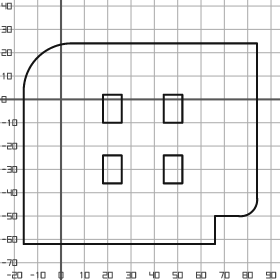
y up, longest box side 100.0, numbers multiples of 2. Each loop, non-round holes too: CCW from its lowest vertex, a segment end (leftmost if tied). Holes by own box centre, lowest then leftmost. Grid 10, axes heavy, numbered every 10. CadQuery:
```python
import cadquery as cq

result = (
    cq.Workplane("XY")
    .moveTo(-16.0, -62.0)
    .lineTo(66.0, -62.0)
    .lineTo(66.0, -50.0)
    .lineTo(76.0, -50.0)
    .threePointArc((82.0, -48.0), (84.0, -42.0))
    .lineTo(84.0, 24.0)
    .lineTo(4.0, 24.0)
    .threePointArc((-10.0, 18.0), (-16.0, 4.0))
    .close()
    .moveTo(18.0, -36.0)
    .lineTo(26.0, -36.0)
    .lineTo(26.0, -24.0)
    .lineTo(18.0, -24.0)
    .close()
    .moveTo(44.0, -36.0)
    .lineTo(52.0, -36.0)
    .lineTo(52.0, -24.0)
    .lineTo(44.0, -24.0)
    .close()
    .moveTo(18.0, -10.0)
    .lineTo(26.0, -10.0)
    .lineTo(26.0, 2.0)
    .lineTo(18.0, 2.0)
    .close()
    .moveTo(44.0, -10.0)
    .lineTo(52.0, -10.0)
    .lineTo(52.0, 2.0)
    .lineTo(44.0, 2.0)
    .close()
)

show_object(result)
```